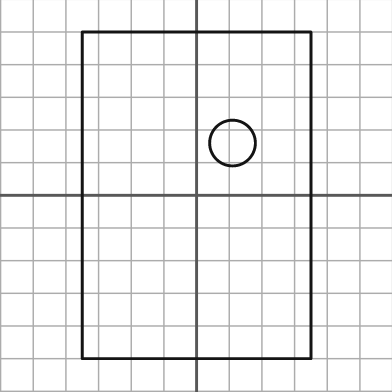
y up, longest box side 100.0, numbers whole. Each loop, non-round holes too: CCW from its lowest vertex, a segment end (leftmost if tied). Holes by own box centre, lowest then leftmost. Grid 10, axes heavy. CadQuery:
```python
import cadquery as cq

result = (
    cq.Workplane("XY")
    .moveTo(-35.0, -50.0)
    .lineTo(35.0, -50.0)
    .lineTo(35.0, 50.0)
    .lineTo(-35.0, 50.0)
    .close()
    .moveTo(11.0, 16.0)
    .circle(7.0)
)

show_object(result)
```